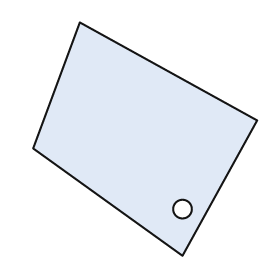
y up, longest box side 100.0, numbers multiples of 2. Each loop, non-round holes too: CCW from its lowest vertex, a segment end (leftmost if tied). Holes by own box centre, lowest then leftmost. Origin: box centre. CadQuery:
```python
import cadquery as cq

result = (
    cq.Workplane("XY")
    .moveTo(16.0, -50.0)
    .lineTo(48.0, 8.0)
    .lineTo(-28.0, 50.0)
    .lineTo(-48.0, -4.0)
    .close()
    .moveTo(16.0, -30.0)
    .circle(4.0)
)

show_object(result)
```